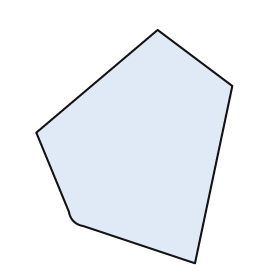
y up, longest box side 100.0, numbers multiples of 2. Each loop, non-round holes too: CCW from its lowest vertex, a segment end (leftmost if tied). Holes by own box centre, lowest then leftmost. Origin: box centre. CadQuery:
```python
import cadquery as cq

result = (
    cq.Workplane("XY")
    .moveTo(26.0, -50.0)
    .lineTo(42.0, 26.0)
    .lineTo(10.0, 50.0)
    .lineTo(-42.0, 6.0)
    .lineTo(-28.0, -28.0)
    .threePointArc((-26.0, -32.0), (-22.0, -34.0))
    .close()
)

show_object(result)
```